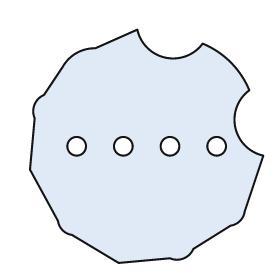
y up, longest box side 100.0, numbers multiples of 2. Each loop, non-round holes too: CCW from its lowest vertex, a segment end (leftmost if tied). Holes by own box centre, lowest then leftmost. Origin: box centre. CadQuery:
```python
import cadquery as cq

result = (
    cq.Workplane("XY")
    .moveTo(-12.0, -50.0)
    .lineTo(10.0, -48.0)
    .threePointArc((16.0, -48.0), (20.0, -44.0))
    .lineTo(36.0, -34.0)
    .threePointArc((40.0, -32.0), (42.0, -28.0))
    .lineTo(50.0, -4.0)
    .threePointArc((38.0, 8.0), (44.0, 24.0))
    .threePointArc((36.0, 36.0), (24.0, 44.0))
    .threePointArc((8.0, 38.0), (-4.0, 50.0))
    .lineTo(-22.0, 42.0)
    .threePointArc((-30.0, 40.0), (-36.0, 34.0))
    .lineTo(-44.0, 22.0)
    .threePointArc((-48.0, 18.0), (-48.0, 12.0))
    .lineTo(-50.0, -10.0)
    .lineTo(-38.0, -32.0)
    .threePointArc((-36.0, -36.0), (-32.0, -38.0))
    .close()
    .moveTo(-30.0, 0.0)
    .circle(4.0)
    .moveTo(-10.0, 0.0)
    .circle(4.0)
    .moveTo(10.0, 0.0)
    .circle(4.0)
    .moveTo(30.0, 0.0)
    .circle(4.0)
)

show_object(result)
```